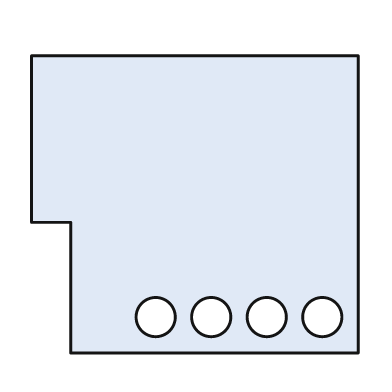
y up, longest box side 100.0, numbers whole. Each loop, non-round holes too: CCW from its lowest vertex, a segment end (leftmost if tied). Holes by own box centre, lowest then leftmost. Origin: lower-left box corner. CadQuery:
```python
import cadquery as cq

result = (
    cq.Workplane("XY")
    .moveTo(12.0, 0.0)
    .lineTo(100.0, 0.0)
    .lineTo(100.0, 91.0)
    .lineTo(0.0, 91.0)
    .lineTo(0.0, 40.0)
    .lineTo(12.0, 40.0)
    .close()
    .moveTo(38.0, 11.0)
    .circle(6.0)
    .moveTo(55.0, 11.0)
    .circle(6.0)
    .moveTo(72.0, 11.0)
    .circle(6.0)
    .moveTo(89.0, 11.0)
    .circle(6.0)
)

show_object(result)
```